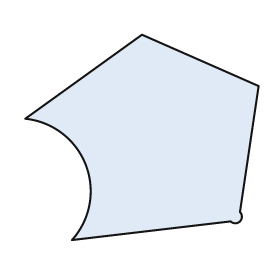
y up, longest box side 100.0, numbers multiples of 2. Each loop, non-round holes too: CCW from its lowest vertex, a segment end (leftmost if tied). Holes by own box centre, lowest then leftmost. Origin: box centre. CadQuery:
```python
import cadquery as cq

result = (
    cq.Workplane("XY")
    .moveTo(-30.0, -44.0)
    .lineTo(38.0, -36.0)
    .threePointArc((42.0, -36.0), (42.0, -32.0))
    .lineTo(50.0, 22.0)
    .lineTo(0.0, 44.0)
    .lineTo(-50.0, 8.0)
    .threePointArc((-24.0, -12.0), (-30.0, -44.0))
    .close()
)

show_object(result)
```